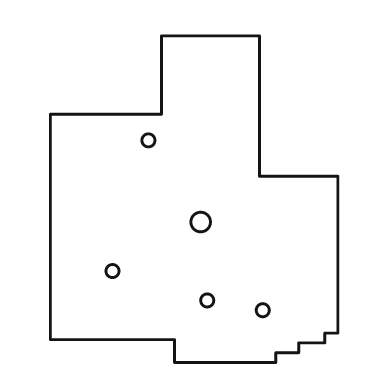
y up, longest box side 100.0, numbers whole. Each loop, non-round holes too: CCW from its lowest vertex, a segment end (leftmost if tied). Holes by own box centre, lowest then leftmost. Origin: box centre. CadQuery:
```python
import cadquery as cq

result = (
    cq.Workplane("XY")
    .moveTo(-6.0, -50.0)
    .lineTo(25.0, -50.0)
    .lineTo(25.0, -47.0)
    .lineTo(32.0, -47.0)
    .lineTo(32.0, -44.0)
    .lineTo(40.0, -44.0)
    .lineTo(40.0, -41.0)
    .lineTo(44.0, -41.0)
    .lineTo(44.0, 7.0)
    .lineTo(20.0, 7.0)
    .lineTo(20.0, 50.0)
    .lineTo(-10.0, 50.0)
    .lineTo(-10.0, 26.0)
    .lineTo(-44.0, 26.0)
    .lineTo(-44.0, -43.0)
    .lineTo(-6.0, -43.0)
    .close()
    .moveTo(21.0, -34.0)
    .circle(2.0)
    .moveTo(4.0, -31.0)
    .circle(2.0)
    .moveTo(-25.0, -22.0)
    .circle(2.0)
    .moveTo(2.0, -7.0)
    .circle(3.0)
    .moveTo(-14.0, 18.0)
    .circle(2.0)
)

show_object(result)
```